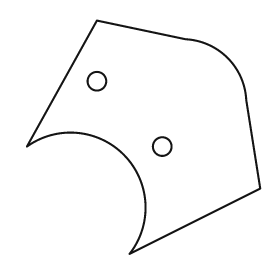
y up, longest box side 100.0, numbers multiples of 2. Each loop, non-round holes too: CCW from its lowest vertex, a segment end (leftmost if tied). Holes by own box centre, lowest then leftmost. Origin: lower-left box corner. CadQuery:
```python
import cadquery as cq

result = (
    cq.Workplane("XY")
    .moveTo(44.0, 0.0)
    .lineTo(100.0, 28.0)
    .lineTo(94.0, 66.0)
    .threePointArc((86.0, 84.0), (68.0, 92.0))
    .lineTo(30.0, 100.0)
    .lineTo(0.0, 46.0)
    .threePointArc((42.0, 42.0), (44.0, 0.0))
    .close()
    .moveTo(58.0, 46.0)
    .circle(4.0)
    .moveTo(30.0, 74.0)
    .circle(4.0)
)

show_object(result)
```